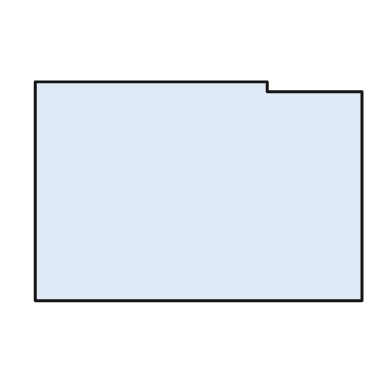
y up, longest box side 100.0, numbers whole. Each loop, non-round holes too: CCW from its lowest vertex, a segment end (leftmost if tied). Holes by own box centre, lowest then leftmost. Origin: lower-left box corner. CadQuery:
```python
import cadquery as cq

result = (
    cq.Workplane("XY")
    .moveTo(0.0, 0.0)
    .lineTo(100.0, 0.0)
    .lineTo(100.0, 64.0)
    .lineTo(71.0, 64.0)
    .lineTo(71.0, 67.0)
    .lineTo(0.0, 67.0)
    .close()
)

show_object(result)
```